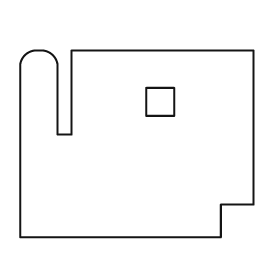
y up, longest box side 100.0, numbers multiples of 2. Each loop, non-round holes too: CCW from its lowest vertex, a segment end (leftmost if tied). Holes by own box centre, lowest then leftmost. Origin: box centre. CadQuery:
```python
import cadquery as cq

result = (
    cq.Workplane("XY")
    .moveTo(-50.0, -40.0)
    .lineTo(36.0, -40.0)
    .lineTo(36.0, -26.0)
    .lineTo(50.0, -26.0)
    .lineTo(50.0, 40.0)
    .lineTo(-28.0, 40.0)
    .lineTo(-28.0, 4.0)
    .lineTo(-34.0, 4.0)
    .lineTo(-34.0, 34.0)
    .threePointArc((-36.0, 38.0), (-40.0, 40.0))
    .lineTo(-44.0, 40.0)
    .threePointArc((-48.0, 38.0), (-50.0, 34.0))
    .close()
    .moveTo(4.0, 12.0)
    .lineTo(16.0, 12.0)
    .lineTo(16.0, 24.0)
    .lineTo(4.0, 24.0)
    .close()
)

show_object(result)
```